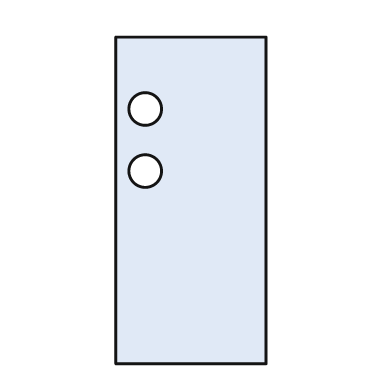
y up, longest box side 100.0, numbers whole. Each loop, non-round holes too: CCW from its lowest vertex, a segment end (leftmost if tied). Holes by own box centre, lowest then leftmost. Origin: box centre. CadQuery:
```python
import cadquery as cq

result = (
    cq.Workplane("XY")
    .moveTo(-23.0, -50.0)
    .lineTo(23.0, -50.0)
    .lineTo(23.0, 50.0)
    .lineTo(-23.0, 50.0)
    .close()
    .moveTo(-14.0, 9.0)
    .circle(5.0)
    .moveTo(-14.0, 28.0)
    .circle(5.0)
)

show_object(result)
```